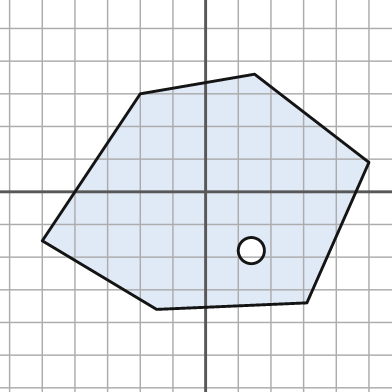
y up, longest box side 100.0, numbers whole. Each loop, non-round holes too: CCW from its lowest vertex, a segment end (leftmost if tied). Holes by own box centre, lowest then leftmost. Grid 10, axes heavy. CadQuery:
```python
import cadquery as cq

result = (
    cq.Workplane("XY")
    .moveTo(-15.0, -36.0)
    .lineTo(31.0, -34.0)
    .lineTo(50.0, 9.0)
    .lineTo(15.0, 36.0)
    .lineTo(-20.0, 30.0)
    .lineTo(-50.0, -15.0)
    .close()
    .moveTo(14.0, -18.0)
    .circle(4.0)
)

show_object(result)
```